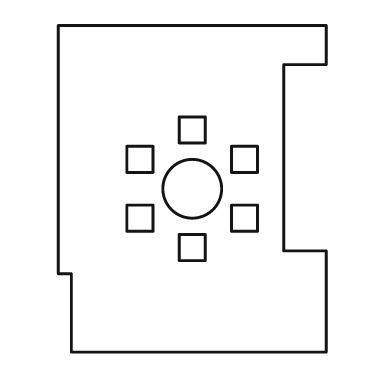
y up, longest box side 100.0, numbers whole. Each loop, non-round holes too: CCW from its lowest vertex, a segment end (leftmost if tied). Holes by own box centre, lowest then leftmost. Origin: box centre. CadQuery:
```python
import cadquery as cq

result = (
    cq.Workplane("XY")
    .moveTo(-37.0, -50.0)
    .lineTo(41.0, -50.0)
    .lineTo(41.0, -19.0)
    .lineTo(28.0, -19.0)
    .lineTo(28.0, 38.0)
    .lineTo(41.0, 38.0)
    .lineTo(41.0, 50.0)
    .lineTo(-41.0, 50.0)
    .lineTo(-41.0, -26.0)
    .lineTo(-37.0, -26.0)
    .close()
    .moveTo(-4.0, -22.0)
    .lineTo(4.0, -22.0)
    .lineTo(4.0, -14.0)
    .lineTo(-4.0, -14.0)
    .close()
    .moveTo(-20.0, -13.0)
    .lineTo(-12.0, -13.0)
    .lineTo(-12.0, -5.0)
    .lineTo(-20.0, -5.0)
    .close()
    .moveTo(12.0, -13.0)
    .lineTo(20.0, -13.0)
    .lineTo(20.0, -5.0)
    .lineTo(12.0, -5.0)
    .close()
    .moveTo(0.0, 0.0)
    .circle(9.0)
    .moveTo(-20.0, 5.0)
    .lineTo(-12.0, 5.0)
    .lineTo(-12.0, 13.0)
    .lineTo(-20.0, 13.0)
    .close()
    .moveTo(12.0, 5.0)
    .lineTo(20.0, 5.0)
    .lineTo(20.0, 13.0)
    .lineTo(12.0, 13.0)
    .close()
    .moveTo(-4.0, 14.0)
    .lineTo(4.0, 14.0)
    .lineTo(4.0, 22.0)
    .lineTo(-4.0, 22.0)
    .close()
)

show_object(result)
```